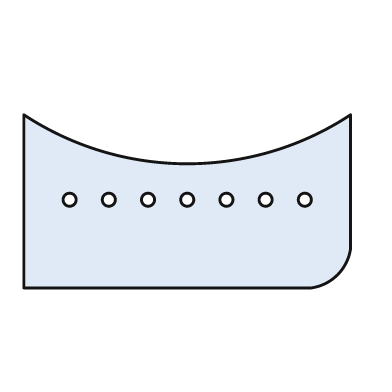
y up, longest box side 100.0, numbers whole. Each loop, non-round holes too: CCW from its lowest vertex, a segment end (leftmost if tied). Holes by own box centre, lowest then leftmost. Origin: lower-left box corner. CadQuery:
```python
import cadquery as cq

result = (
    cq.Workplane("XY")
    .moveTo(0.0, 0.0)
    .lineTo(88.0, 0.0)
    .threePointArc((96.0, 4.0), (100.0, 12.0))
    .lineTo(100.0, 53.0)
    .threePointArc((50.0, 38.0), (0.0, 53.0))
    .close()
    .moveTo(14.0, 27.0)
    .circle(2.0)
    .moveTo(26.0, 27.0)
    .circle(2.0)
    .moveTo(38.0, 27.0)
    .circle(2.0)
    .moveTo(50.0, 27.0)
    .circle(2.0)
    .moveTo(62.0, 27.0)
    .circle(2.0)
    .moveTo(74.0, 27.0)
    .circle(2.0)
    .moveTo(86.0, 27.0)
    .circle(2.0)
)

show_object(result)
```